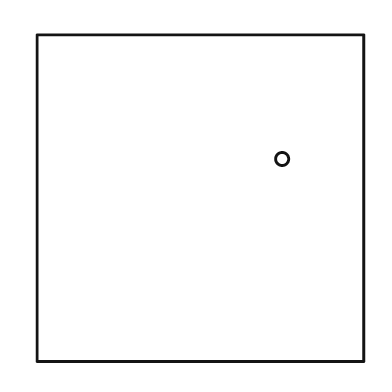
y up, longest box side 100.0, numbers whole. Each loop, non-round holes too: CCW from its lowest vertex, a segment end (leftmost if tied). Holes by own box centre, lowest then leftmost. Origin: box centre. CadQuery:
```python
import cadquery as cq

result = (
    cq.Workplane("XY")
    .moveTo(-50.0, -50.0)
    .lineTo(50.0, -50.0)
    .lineTo(50.0, 50.0)
    .lineTo(-50.0, 50.0)
    .close()
    .moveTo(25.0, 12.0)
    .circle(2.0)
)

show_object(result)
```